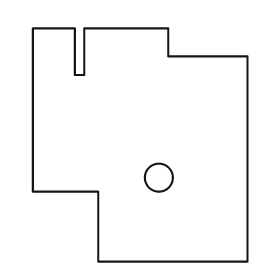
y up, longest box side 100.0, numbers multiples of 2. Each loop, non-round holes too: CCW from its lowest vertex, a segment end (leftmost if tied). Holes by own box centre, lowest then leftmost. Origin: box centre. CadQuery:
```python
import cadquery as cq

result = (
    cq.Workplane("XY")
    .moveTo(-18.0, -50.0)
    .lineTo(46.0, -50.0)
    .lineTo(46.0, 38.0)
    .lineTo(12.0, 38.0)
    .lineTo(12.0, 50.0)
    .lineTo(-24.0, 50.0)
    .lineTo(-24.0, 30.0)
    .lineTo(-28.0, 30.0)
    .lineTo(-28.0, 50.0)
    .lineTo(-46.0, 50.0)
    .lineTo(-46.0, -20.0)
    .lineTo(-18.0, -20.0)
    .close()
    .moveTo(8.0, -14.0)
    .circle(6.0)
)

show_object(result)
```